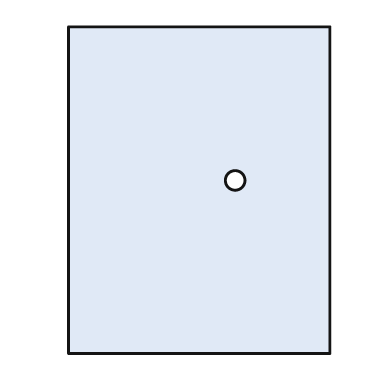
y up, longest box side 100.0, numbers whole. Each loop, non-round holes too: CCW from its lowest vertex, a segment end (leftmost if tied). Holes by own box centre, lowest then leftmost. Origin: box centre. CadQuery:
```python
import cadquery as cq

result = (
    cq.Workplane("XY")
    .moveTo(-40.0, -50.0)
    .lineTo(40.0, -50.0)
    .lineTo(40.0, 50.0)
    .lineTo(-40.0, 50.0)
    .close()
    .moveTo(11.0, 3.0)
    .circle(3.0)
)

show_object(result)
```